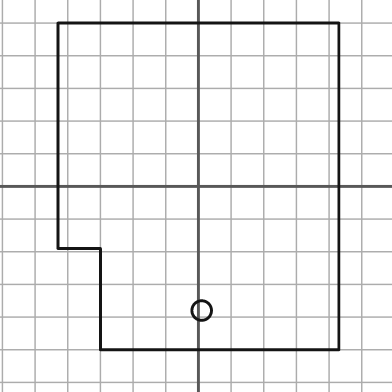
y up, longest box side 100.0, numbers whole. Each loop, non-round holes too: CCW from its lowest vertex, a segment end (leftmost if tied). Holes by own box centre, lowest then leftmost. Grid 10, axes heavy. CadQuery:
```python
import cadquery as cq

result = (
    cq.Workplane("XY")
    .moveTo(-30.0, -50.0)
    .lineTo(43.0, -50.0)
    .lineTo(43.0, 50.0)
    .lineTo(-43.0, 50.0)
    .lineTo(-43.0, -19.0)
    .lineTo(-30.0, -19.0)
    .close()
    .moveTo(1.0, -38.0)
    .circle(3.0)
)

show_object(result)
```